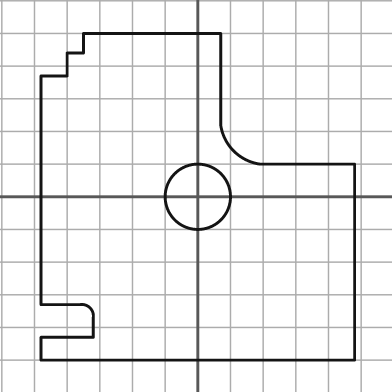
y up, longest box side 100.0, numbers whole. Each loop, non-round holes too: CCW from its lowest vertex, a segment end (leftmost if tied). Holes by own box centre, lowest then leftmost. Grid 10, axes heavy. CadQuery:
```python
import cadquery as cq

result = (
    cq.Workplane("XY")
    .moveTo(-48.0, -50.0)
    .lineTo(48.0, -50.0)
    .lineTo(48.0, 10.0)
    .lineTo(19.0, 10.0)
    .threePointArc((11.0, 14.0), (7.0, 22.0))
    .lineTo(7.0, 50.0)
    .lineTo(-35.0, 50.0)
    .lineTo(-35.0, 44.0)
    .lineTo(-40.0, 44.0)
    .lineTo(-40.0, 37.0)
    .lineTo(-48.0, 37.0)
    .lineTo(-48.0, -33.0)
    .lineTo(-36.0, -33.0)
    .threePointArc((-33.0, -34.0), (-32.0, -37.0))
    .lineTo(-32.0, -43.0)
    .lineTo(-48.0, -43.0)
    .close()
    .moveTo(0.0, 0.0)
    .circle(10.0)
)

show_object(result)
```